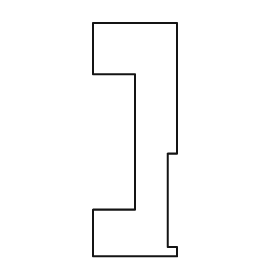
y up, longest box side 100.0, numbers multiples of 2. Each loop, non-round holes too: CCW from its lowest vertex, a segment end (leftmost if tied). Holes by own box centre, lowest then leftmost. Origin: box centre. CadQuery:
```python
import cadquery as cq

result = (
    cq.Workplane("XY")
    .moveTo(-18.0, -50.0)
    .lineTo(18.0, -50.0)
    .lineTo(18.0, -46.0)
    .lineTo(14.0, -46.0)
    .lineTo(14.0, -6.0)
    .lineTo(18.0, -6.0)
    .lineTo(18.0, 50.0)
    .lineTo(-18.0, 50.0)
    .lineTo(-18.0, 28.0)
    .lineTo(0.0, 28.0)
    .lineTo(0.0, -30.0)
    .lineTo(-18.0, -30.0)
    .close()
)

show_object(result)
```